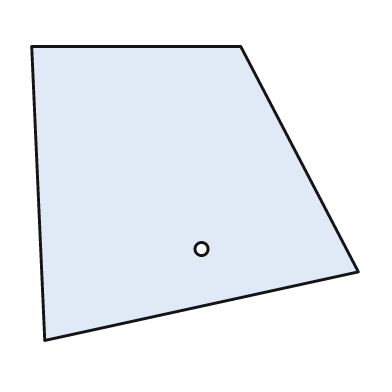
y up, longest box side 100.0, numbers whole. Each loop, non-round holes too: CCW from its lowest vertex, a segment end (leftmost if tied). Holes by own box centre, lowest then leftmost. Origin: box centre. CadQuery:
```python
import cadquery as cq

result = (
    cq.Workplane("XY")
    .moveTo(-46.0, -45.0)
    .lineTo(50.0, -24.0)
    .lineTo(14.0, 45.0)
    .lineTo(-50.0, 45.0)
    .close()
    .moveTo(2.0, -17.0)
    .circle(2.0)
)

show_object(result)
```